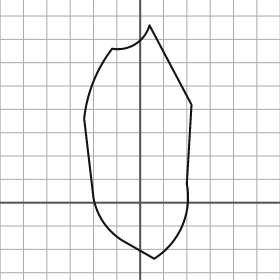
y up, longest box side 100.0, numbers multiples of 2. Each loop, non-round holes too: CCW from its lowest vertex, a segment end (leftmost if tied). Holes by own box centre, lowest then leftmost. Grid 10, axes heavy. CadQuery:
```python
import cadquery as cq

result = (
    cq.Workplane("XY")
    .moveTo(6.0, -24.0)
    .threePointArc((18.0, -10.0), (20.0, 8.0))
    .lineTo(22.0, 42.0)
    .lineTo(4.0, 76.0)
    .threePointArc((-2.0, 68.0), (-12.0, 66.0))
    .threePointArc((-20.0, 52.0), (-24.0, 36.0))
    .lineTo(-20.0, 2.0)
    .threePointArc((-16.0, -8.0), (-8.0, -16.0))
    .close()
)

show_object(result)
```